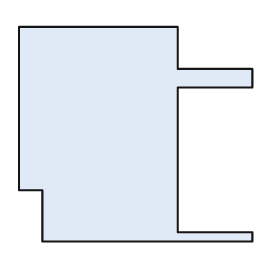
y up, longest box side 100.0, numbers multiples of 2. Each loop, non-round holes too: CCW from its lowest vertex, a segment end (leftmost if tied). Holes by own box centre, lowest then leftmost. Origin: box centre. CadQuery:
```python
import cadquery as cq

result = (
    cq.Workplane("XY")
    .moveTo(-40.0, -46.0)
    .lineTo(50.0, -46.0)
    .lineTo(50.0, -42.0)
    .lineTo(18.0, -42.0)
    .lineTo(18.0, 20.0)
    .lineTo(50.0, 20.0)
    .lineTo(50.0, 28.0)
    .lineTo(18.0, 28.0)
    .lineTo(18.0, 46.0)
    .lineTo(-50.0, 46.0)
    .lineTo(-50.0, -24.0)
    .lineTo(-40.0, -24.0)
    .close()
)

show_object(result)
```